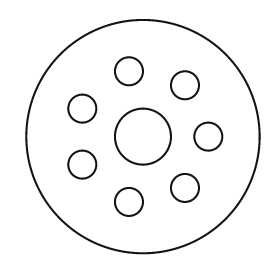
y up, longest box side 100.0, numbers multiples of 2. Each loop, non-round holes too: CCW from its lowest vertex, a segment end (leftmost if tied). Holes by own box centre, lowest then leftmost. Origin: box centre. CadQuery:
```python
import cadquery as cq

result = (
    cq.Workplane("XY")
    .moveTo(0.0, 0.0)
    .circle(50.0)
    .moveTo(-6.0, -28.0)
    .circle(6.0)
    .moveTo(18.0, -22.0)
    .circle(6.0)
    .moveTo(-26.0, -12.0)
    .circle(6.0)
    .moveTo(0.0, 0.0)
    .circle(12.0)
    .moveTo(28.0, 0.0)
    .circle(6.0)
    .moveTo(-26.0, 12.0)
    .circle(6.0)
    .moveTo(18.0, 22.0)
    .circle(6.0)
    .moveTo(-6.0, 28.0)
    .circle(6.0)
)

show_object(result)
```